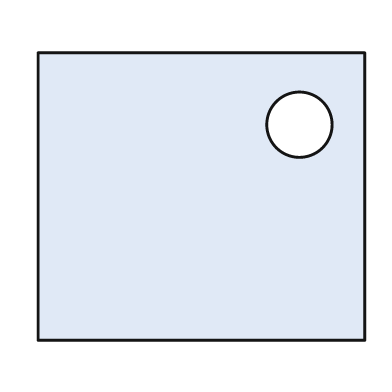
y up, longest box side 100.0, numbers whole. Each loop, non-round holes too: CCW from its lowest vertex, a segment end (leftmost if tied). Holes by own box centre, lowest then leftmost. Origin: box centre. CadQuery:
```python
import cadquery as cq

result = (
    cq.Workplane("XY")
    .moveTo(-50.0, -44.0)
    .lineTo(50.0, -44.0)
    .lineTo(50.0, 44.0)
    .lineTo(-50.0, 44.0)
    .close()
    .moveTo(30.0, 22.0)
    .circle(10.0)
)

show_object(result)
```